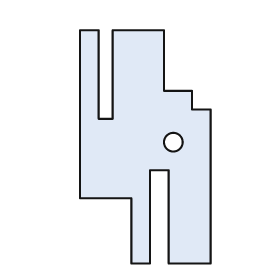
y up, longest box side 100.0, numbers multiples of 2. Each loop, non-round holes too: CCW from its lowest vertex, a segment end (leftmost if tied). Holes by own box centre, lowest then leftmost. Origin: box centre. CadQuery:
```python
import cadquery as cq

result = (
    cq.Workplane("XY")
    .moveTo(-6.0, -50.0)
    .lineTo(2.0, -50.0)
    .lineTo(2.0, -10.0)
    .lineTo(10.0, -10.0)
    .lineTo(10.0, -50.0)
    .lineTo(28.0, -50.0)
    .lineTo(28.0, 16.0)
    .lineTo(20.0, 16.0)
    .lineTo(20.0, 24.0)
    .lineTo(8.0, 24.0)
    .lineTo(8.0, 50.0)
    .lineTo(-14.0, 50.0)
    .lineTo(-14.0, 12.0)
    .lineTo(-20.0, 12.0)
    .lineTo(-20.0, 50.0)
    .lineTo(-28.0, 50.0)
    .lineTo(-28.0, -22.0)
    .lineTo(-6.0, -22.0)
    .close()
    .moveTo(12.0, 2.0)
    .circle(4.0)
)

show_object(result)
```